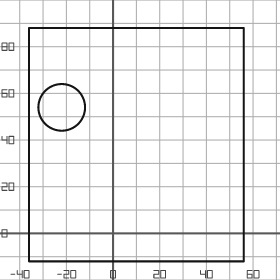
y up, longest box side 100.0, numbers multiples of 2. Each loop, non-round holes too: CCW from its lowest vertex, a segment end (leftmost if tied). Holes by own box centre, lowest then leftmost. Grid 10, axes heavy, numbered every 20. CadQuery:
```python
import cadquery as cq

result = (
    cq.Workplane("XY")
    .moveTo(-36.0, -12.0)
    .lineTo(56.0, -12.0)
    .lineTo(56.0, 88.0)
    .lineTo(-36.0, 88.0)
    .close()
    .moveTo(-22.0, 54.0)
    .circle(10.0)
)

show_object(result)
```